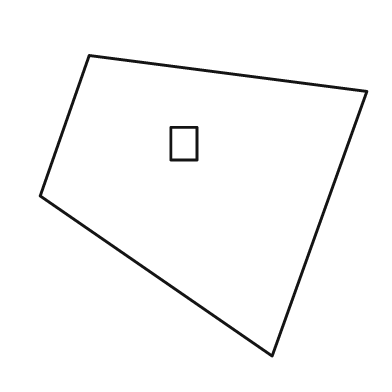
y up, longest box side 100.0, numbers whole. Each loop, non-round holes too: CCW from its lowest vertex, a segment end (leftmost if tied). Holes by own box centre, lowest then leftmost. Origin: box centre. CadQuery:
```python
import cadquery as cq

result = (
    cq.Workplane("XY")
    .moveTo(21.0, -46.0)
    .lineTo(50.0, 35.0)
    .lineTo(-35.0, 46.0)
    .lineTo(-50.0, 3.0)
    .close()
    .moveTo(-10.0, 14.0)
    .lineTo(-2.0, 14.0)
    .lineTo(-2.0, 24.0)
    .lineTo(-10.0, 24.0)
    .close()
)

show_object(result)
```